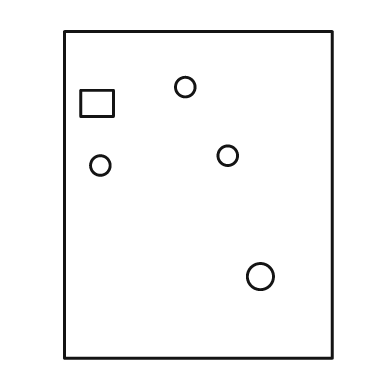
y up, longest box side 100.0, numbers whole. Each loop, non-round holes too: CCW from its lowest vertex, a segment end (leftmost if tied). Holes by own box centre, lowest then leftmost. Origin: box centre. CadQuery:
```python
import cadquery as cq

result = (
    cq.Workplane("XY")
    .moveTo(-41.0, -50.0)
    .lineTo(41.0, -50.0)
    .lineTo(41.0, 50.0)
    .lineTo(-41.0, 50.0)
    .close()
    .moveTo(19.0, -25.0)
    .circle(4.0)
    .moveTo(-30.0, 9.0)
    .circle(3.0)
    .moveTo(9.0, 12.0)
    .circle(3.0)
    .moveTo(-36.0, 24.0)
    .lineTo(-26.0, 24.0)
    .lineTo(-26.0, 32.0)
    .lineTo(-36.0, 32.0)
    .close()
    .moveTo(-4.0, 33.0)
    .circle(3.0)
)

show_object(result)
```